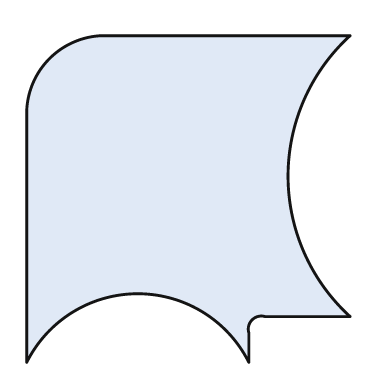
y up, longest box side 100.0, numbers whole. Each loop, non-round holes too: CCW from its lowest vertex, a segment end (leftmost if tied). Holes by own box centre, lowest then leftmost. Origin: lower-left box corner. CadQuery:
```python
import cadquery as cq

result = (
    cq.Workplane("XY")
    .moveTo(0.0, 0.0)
    .threePointArc((34.0, 21.0), (68.0, 0.0))
    .lineTo(68.0, 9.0)
    .threePointArc((69.0, 13.0), (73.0, 14.0))
    .lineTo(99.0, 14.0)
    .threePointArc((80.0, 57.0), (99.0, 100.0))
    .lineTo(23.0, 100.0)
    .threePointArc((7.0, 93.0), (0.0, 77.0))
    .close()
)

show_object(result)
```